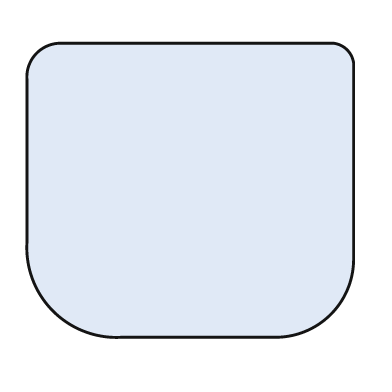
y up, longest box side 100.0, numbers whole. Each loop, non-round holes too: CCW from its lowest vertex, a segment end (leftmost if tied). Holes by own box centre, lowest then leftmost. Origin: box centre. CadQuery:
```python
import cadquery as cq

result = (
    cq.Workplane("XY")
    .moveTo(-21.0, -45.0)
    .lineTo(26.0, -45.0)
    .threePointArc((43.0, -38.0), (50.0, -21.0))
    .lineTo(50.0, 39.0)
    .threePointArc((48.0, 43.0), (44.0, 45.0))
    .lineTo(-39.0, 45.0)
    .threePointArc((-47.0, 42.0), (-50.0, 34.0))
    .lineTo(-50.0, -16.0)
    .threePointArc((-42.0, -37.0), (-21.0, -45.0))
    .close()
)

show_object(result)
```